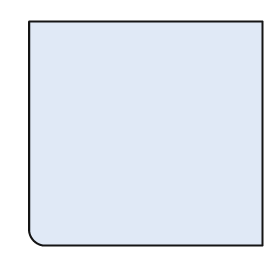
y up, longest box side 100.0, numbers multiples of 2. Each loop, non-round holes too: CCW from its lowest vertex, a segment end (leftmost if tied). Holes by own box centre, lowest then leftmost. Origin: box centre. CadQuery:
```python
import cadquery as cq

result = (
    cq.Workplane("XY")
    .moveTo(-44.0, -48.0)
    .lineTo(50.0, -48.0)
    .lineTo(50.0, 48.0)
    .lineTo(-50.0, 48.0)
    .lineTo(-50.0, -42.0)
    .threePointArc((-48.0, -46.0), (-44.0, -48.0))
    .close()
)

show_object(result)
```